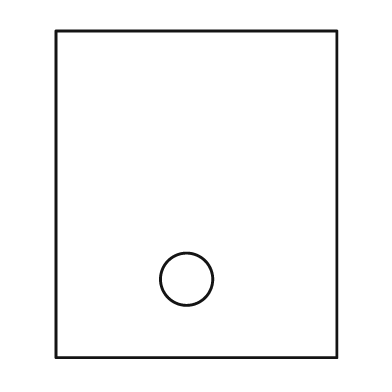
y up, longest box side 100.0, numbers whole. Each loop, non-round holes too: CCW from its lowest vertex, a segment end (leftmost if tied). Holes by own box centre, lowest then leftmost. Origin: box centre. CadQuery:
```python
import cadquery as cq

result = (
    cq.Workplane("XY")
    .moveTo(-43.0, -50.0)
    .lineTo(43.0, -50.0)
    .lineTo(43.0, 50.0)
    .lineTo(-43.0, 50.0)
    .close()
    .moveTo(-3.0, -26.0)
    .circle(8.0)
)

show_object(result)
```